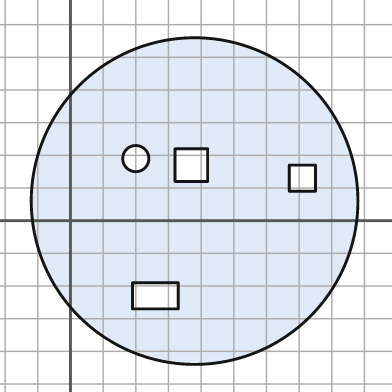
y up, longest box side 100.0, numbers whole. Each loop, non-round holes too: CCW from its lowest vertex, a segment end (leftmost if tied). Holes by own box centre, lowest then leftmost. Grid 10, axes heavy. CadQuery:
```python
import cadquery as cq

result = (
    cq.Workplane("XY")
    .moveTo(38.0, 6.0)
    .circle(50.0)
    .moveTo(19.0, -27.0)
    .lineTo(33.0, -27.0)
    .lineTo(33.0, -19.0)
    .lineTo(19.0, -19.0)
    .close()
    .moveTo(67.0, 9.0)
    .lineTo(75.0, 9.0)
    .lineTo(75.0, 17.0)
    .lineTo(67.0, 17.0)
    .close()
    .moveTo(32.0, 12.0)
    .lineTo(42.0, 12.0)
    .lineTo(42.0, 22.0)
    .lineTo(32.0, 22.0)
    .close()
    .moveTo(20.0, 19.0)
    .circle(4.0)
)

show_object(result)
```